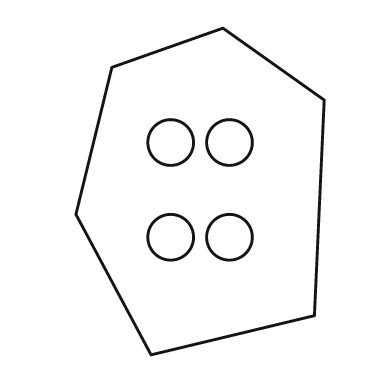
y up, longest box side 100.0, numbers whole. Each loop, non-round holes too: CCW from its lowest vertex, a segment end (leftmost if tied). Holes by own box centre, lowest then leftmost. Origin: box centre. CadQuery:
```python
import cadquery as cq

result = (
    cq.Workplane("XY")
    .moveTo(-15.0, -50.0)
    .lineTo(35.0, -38.0)
    .lineTo(38.0, 28.0)
    .lineTo(7.0, 50.0)
    .lineTo(-27.0, 38.0)
    .lineTo(-38.0, -7.0)
    .close()
    .moveTo(-9.0, -14.0)
    .circle(7.0)
    .moveTo(9.0, -14.0)
    .circle(7.0)
    .moveTo(-9.0, 15.0)
    .circle(7.0)
    .moveTo(9.0, 15.0)
    .circle(7.0)
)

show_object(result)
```